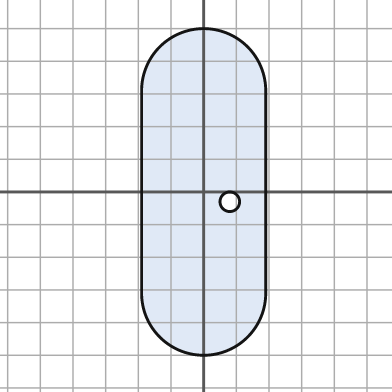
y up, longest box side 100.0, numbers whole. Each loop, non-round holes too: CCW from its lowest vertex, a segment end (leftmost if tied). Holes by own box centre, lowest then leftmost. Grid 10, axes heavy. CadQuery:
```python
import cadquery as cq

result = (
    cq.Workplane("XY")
    .moveTo(-19.0, -31.0)
    .threePointArc((0.0, -50.0), (19.0, -31.0))
    .lineTo(19.0, 31.0)
    .threePointArc((0.0, 50.0), (-19.0, 31.0))
    .close()
    .moveTo(8.0, -3.0)
    .circle(3.0)
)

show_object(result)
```